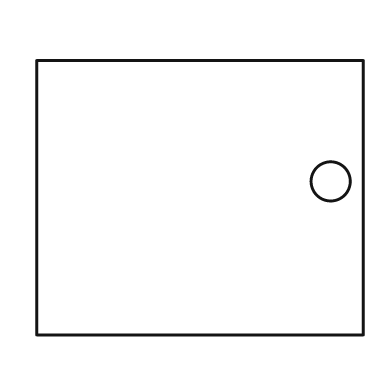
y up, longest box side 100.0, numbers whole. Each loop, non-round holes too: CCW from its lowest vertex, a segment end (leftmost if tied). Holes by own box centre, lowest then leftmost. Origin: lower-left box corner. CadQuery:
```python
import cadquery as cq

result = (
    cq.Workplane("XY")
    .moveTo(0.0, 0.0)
    .lineTo(100.0, 0.0)
    .lineTo(100.0, 84.0)
    .lineTo(0.0, 84.0)
    .close()
    .moveTo(90.0, 47.0)
    .circle(6.0)
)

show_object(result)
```